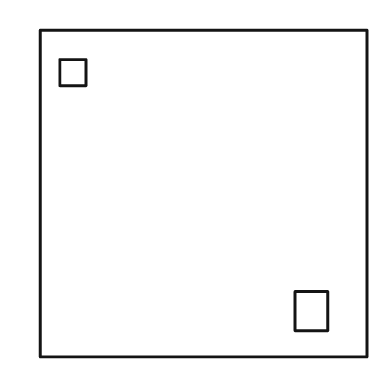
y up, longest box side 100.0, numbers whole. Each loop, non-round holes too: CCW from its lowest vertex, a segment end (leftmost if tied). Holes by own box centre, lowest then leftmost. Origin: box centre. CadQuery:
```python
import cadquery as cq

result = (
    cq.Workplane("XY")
    .moveTo(-50.0, -50.0)
    .lineTo(50.0, -50.0)
    .lineTo(50.0, 50.0)
    .lineTo(-50.0, 50.0)
    .close()
    .moveTo(28.0, -42.0)
    .lineTo(38.0, -42.0)
    .lineTo(38.0, -30.0)
    .lineTo(28.0, -30.0)
    .close()
    .moveTo(-44.0, 33.0)
    .lineTo(-36.0, 33.0)
    .lineTo(-36.0, 41.0)
    .lineTo(-44.0, 41.0)
    .close()
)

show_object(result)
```